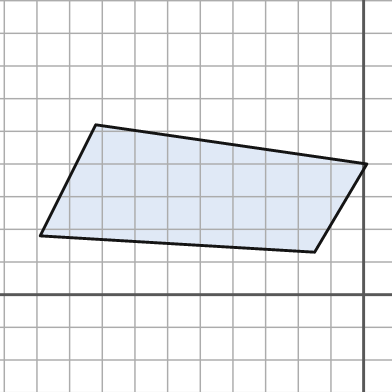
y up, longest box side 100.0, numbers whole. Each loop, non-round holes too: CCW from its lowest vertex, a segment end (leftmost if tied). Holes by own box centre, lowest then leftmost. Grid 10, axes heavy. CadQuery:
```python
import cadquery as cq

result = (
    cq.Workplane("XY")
    .moveTo(-15.0, 13.0)
    .lineTo(1.0, 40.0)
    .lineTo(-82.0, 52.0)
    .lineTo(-99.0, 18.0)
    .close()
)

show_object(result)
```